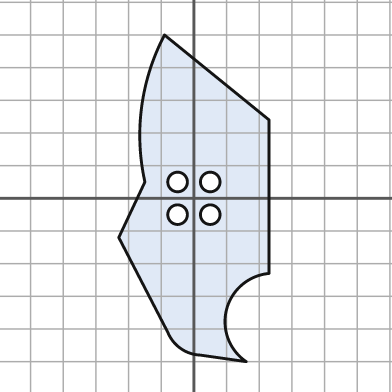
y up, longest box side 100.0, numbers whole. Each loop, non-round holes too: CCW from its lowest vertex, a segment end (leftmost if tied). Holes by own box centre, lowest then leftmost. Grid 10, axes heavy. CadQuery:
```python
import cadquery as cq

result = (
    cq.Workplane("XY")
    .moveTo(16.0, -50.0)
    .threePointArc((10.0, -34.0), (23.0, -23.0))
    .lineTo(23.0, 24.0)
    .lineTo(-9.0, 50.0)
    .threePointArc((-16.0, 28.0), (-15.0, 5.0))
    .lineTo(-23.0, -12.0)
    .lineTo(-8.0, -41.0)
    .threePointArc((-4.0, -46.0), (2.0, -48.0))
    .close()
    .moveTo(-5.0, -5.0)
    .circle(3.0)
    .moveTo(5.0, -5.0)
    .circle(3.0)
    .moveTo(-5.0, 5.0)
    .circle(3.0)
    .moveTo(5.0, 5.0)
    .circle(3.0)
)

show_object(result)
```